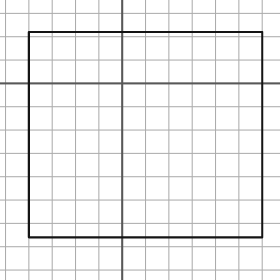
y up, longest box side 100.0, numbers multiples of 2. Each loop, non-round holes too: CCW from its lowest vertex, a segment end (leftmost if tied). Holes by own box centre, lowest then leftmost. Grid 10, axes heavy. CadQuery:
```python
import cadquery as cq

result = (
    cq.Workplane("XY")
    .moveTo(-40.0, -66.0)
    .lineTo(60.0, -66.0)
    .lineTo(60.0, 22.0)
    .lineTo(-40.0, 22.0)
    .close()
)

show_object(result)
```